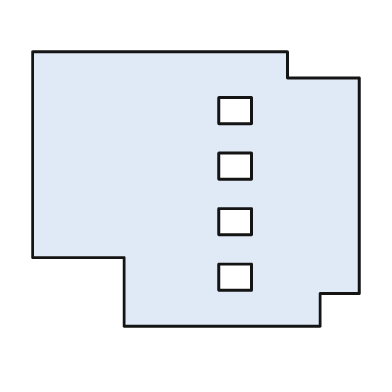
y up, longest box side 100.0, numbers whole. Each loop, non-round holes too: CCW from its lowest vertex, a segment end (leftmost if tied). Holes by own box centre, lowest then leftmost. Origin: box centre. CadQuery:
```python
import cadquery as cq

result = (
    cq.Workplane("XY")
    .moveTo(-22.0, -42.0)
    .lineTo(38.0, -42.0)
    .lineTo(38.0, -32.0)
    .lineTo(50.0, -32.0)
    .lineTo(50.0, 34.0)
    .lineTo(28.0, 34.0)
    .lineTo(28.0, 42.0)
    .lineTo(-50.0, 42.0)
    .lineTo(-50.0, -21.0)
    .lineTo(-22.0, -21.0)
    .close()
    .moveTo(7.0, -31.0)
    .lineTo(17.0, -31.0)
    .lineTo(17.0, -23.0)
    .lineTo(7.0, -23.0)
    .close()
    .moveTo(7.0, -14.0)
    .lineTo(17.0, -14.0)
    .lineTo(17.0, -6.0)
    .lineTo(7.0, -6.0)
    .close()
    .moveTo(7.0, 3.0)
    .lineTo(17.0, 3.0)
    .lineTo(17.0, 11.0)
    .lineTo(7.0, 11.0)
    .close()
    .moveTo(7.0, 20.0)
    .lineTo(17.0, 20.0)
    .lineTo(17.0, 28.0)
    .lineTo(7.0, 28.0)
    .close()
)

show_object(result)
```